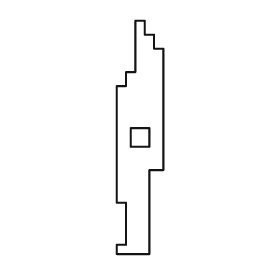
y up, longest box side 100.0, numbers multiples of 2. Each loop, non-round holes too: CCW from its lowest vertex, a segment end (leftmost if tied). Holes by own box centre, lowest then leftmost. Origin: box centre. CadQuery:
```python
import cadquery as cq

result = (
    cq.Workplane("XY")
    .moveTo(-10.0, -50.0)
    .lineTo(4.0, -50.0)
    .lineTo(4.0, -14.0)
    .lineTo(10.0, -14.0)
    .lineTo(10.0, 38.0)
    .lineTo(6.0, 38.0)
    .lineTo(6.0, 44.0)
    .lineTo(2.0, 44.0)
    .lineTo(2.0, 50.0)
    .lineTo(-2.0, 50.0)
    .lineTo(-2.0, 28.0)
    .lineTo(-6.0, 28.0)
    .lineTo(-6.0, 22.0)
    .lineTo(-10.0, 22.0)
    .lineTo(-10.0, -28.0)
    .lineTo(-6.0, -28.0)
    .lineTo(-6.0, -46.0)
    .lineTo(-10.0, -46.0)
    .close()
    .moveTo(-4.0, -4.0)
    .lineTo(4.0, -4.0)
    .lineTo(4.0, 4.0)
    .lineTo(-4.0, 4.0)
    .close()
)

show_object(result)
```